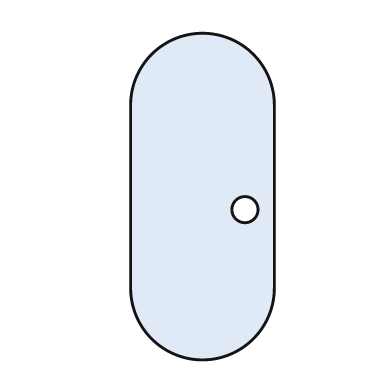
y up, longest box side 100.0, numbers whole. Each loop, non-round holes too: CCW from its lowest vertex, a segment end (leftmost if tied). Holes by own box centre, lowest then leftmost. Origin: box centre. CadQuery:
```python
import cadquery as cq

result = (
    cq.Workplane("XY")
    .moveTo(-22.0, -28.0)
    .threePointArc((0.0, -50.0), (22.0, -28.0))
    .lineTo(22.0, 28.0)
    .threePointArc((0.0, 50.0), (-22.0, 28.0))
    .close()
    .moveTo(13.0, -4.0)
    .circle(4.0)
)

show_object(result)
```